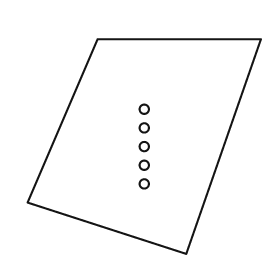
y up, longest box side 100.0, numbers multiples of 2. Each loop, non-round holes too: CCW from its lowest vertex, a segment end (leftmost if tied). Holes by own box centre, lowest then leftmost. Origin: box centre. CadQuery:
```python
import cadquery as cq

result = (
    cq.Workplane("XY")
    .moveTo(18.0, -46.0)
    .lineTo(50.0, 46.0)
    .lineTo(-20.0, 46.0)
    .lineTo(-50.0, -24.0)
    .close()
    .moveTo(0.0, -16.0)
    .circle(2.0)
    .moveTo(0.0, -8.0)
    .circle(2.0)
    .moveTo(0.0, 0.0)
    .circle(2.0)
    .moveTo(0.0, 8.0)
    .circle(2.0)
    .moveTo(0.0, 16.0)
    .circle(2.0)
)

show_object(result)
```